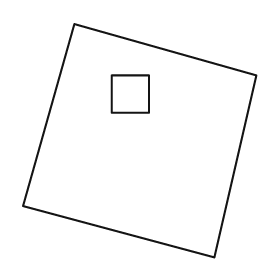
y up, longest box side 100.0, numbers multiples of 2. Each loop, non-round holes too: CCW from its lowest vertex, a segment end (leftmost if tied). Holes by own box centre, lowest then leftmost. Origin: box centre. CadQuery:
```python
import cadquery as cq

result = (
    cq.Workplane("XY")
    .moveTo(32.0, -50.0)
    .lineTo(50.0, 28.0)
    .lineTo(-28.0, 50.0)
    .lineTo(-50.0, -28.0)
    .close()
    .moveTo(-12.0, 12.0)
    .lineTo(4.0, 12.0)
    .lineTo(4.0, 28.0)
    .lineTo(-12.0, 28.0)
    .close()
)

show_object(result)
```